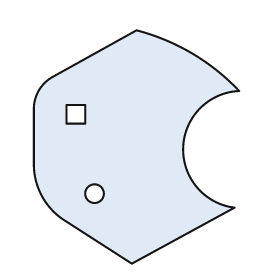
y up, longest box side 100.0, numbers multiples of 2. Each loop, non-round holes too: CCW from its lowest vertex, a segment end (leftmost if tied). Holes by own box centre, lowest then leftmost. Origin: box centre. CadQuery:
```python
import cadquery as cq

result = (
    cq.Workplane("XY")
    .moveTo(-2.0, -50.0)
    .lineTo(42.0, -26.0)
    .threePointArc((20.0, 0.0), (44.0, 24.0))
    .threePointArc((24.0, 40.0), (0.0, 50.0))
    .lineTo(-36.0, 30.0)
    .threePointArc((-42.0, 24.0), (-44.0, 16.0))
    .lineTo(-44.0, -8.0)
    .threePointArc((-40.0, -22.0), (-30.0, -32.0))
    .close()
    .moveTo(-18.0, -20.0)
    .circle(4.0)
    .moveTo(-30.0, 10.0)
    .lineTo(-22.0, 10.0)
    .lineTo(-22.0, 18.0)
    .lineTo(-30.0, 18.0)
    .close()
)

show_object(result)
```